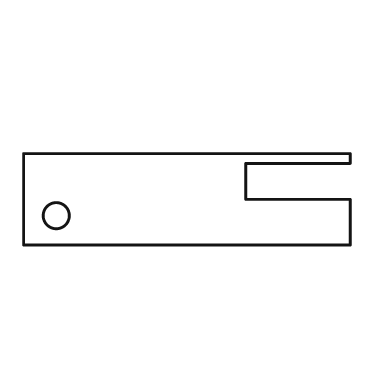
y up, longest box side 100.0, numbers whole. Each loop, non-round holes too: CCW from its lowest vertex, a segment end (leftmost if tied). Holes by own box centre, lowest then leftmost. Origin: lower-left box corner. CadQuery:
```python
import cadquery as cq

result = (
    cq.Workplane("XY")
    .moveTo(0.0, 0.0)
    .lineTo(100.0, 0.0)
    .lineTo(100.0, 14.0)
    .lineTo(68.0, 14.0)
    .lineTo(68.0, 25.0)
    .lineTo(100.0, 25.0)
    .lineTo(100.0, 28.0)
    .lineTo(0.0, 28.0)
    .close()
    .moveTo(10.0, 9.0)
    .circle(4.0)
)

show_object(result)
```